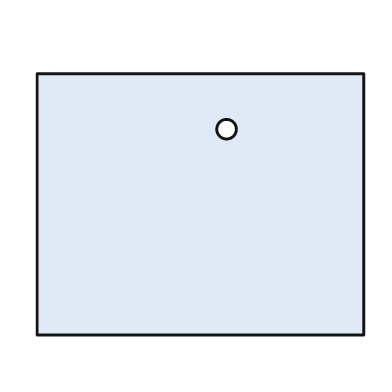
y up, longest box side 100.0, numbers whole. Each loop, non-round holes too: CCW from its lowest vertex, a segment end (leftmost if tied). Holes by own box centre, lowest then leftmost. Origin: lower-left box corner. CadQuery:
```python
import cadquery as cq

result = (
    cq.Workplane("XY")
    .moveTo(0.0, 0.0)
    .lineTo(100.0, 0.0)
    .lineTo(100.0, 80.0)
    .lineTo(0.0, 80.0)
    .close()
    .moveTo(58.0, 63.0)
    .circle(3.0)
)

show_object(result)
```